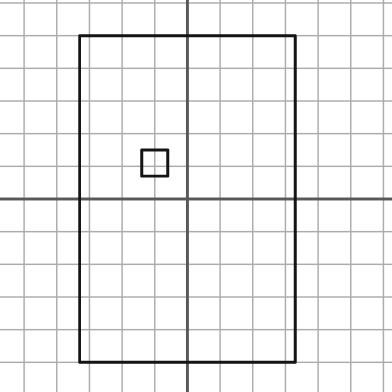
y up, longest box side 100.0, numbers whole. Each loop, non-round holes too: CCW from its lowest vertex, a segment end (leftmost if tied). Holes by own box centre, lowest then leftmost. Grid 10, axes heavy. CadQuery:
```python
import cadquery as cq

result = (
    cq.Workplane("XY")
    .moveTo(-33.0, -50.0)
    .lineTo(33.0, -50.0)
    .lineTo(33.0, 50.0)
    .lineTo(-33.0, 50.0)
    .close()
    .moveTo(-14.0, 7.0)
    .lineTo(-6.0, 7.0)
    .lineTo(-6.0, 15.0)
    .lineTo(-14.0, 15.0)
    .close()
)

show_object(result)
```